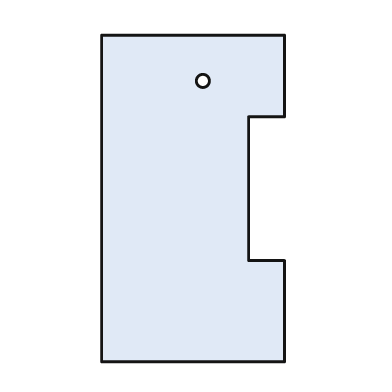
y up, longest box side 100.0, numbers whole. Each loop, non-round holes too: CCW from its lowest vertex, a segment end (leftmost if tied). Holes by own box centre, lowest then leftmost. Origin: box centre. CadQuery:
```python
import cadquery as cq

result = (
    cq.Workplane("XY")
    .moveTo(-28.0, -50.0)
    .lineTo(28.0, -50.0)
    .lineTo(28.0, -19.0)
    .lineTo(17.0, -19.0)
    .lineTo(17.0, 25.0)
    .lineTo(28.0, 25.0)
    .lineTo(28.0, 50.0)
    .lineTo(-28.0, 50.0)
    .close()
    .moveTo(3.0, 36.0)
    .circle(2.0)
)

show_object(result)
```